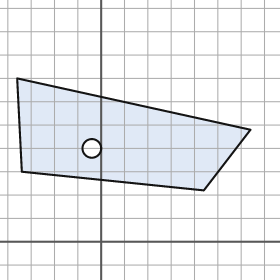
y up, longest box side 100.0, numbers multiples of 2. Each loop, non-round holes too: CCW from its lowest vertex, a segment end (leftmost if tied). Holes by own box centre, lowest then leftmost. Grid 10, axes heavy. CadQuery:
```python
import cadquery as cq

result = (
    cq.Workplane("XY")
    .moveTo(44.0, 22.0)
    .lineTo(64.0, 48.0)
    .lineTo(-36.0, 70.0)
    .lineTo(-34.0, 30.0)
    .close()
    .moveTo(-4.0, 40.0)
    .circle(4.0)
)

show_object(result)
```